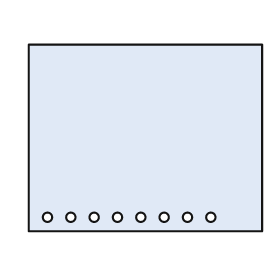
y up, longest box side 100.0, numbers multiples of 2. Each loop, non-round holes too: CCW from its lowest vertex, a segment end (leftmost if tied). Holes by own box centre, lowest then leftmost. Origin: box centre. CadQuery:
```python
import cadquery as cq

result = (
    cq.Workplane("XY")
    .moveTo(-50.0, -40.0)
    .lineTo(50.0, -40.0)
    .lineTo(50.0, 40.0)
    .lineTo(-50.0, 40.0)
    .close()
    .moveTo(-42.0, -34.0)
    .circle(2.0)
    .moveTo(-32.0, -34.0)
    .circle(2.0)
    .moveTo(-22.0, -34.0)
    .circle(2.0)
    .moveTo(-12.0, -34.0)
    .circle(2.0)
    .moveTo(-2.0, -34.0)
    .circle(2.0)
    .moveTo(8.0, -34.0)
    .circle(2.0)
    .moveTo(18.0, -34.0)
    .circle(2.0)
    .moveTo(28.0, -34.0)
    .circle(2.0)
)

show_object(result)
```